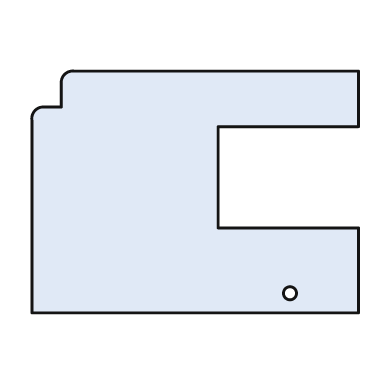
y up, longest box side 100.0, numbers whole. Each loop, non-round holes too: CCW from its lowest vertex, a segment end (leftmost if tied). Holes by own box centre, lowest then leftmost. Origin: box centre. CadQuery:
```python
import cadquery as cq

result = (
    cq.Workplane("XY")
    .moveTo(-50.0, -37.0)
    .lineTo(50.0, -37.0)
    .lineTo(50.0, -11.0)
    .lineTo(7.0, -11.0)
    .lineTo(7.0, 20.0)
    .lineTo(50.0, 20.0)
    .lineTo(50.0, 37.0)
    .lineTo(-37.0, 37.0)
    .threePointArc((-40.0, 36.0), (-41.0, 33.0))
    .lineTo(-41.0, 26.0)
    .lineTo(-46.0, 26.0)
    .threePointArc((-49.0, 25.0), (-50.0, 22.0))
    .close()
    .moveTo(29.0, -31.0)
    .circle(2.0)
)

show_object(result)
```